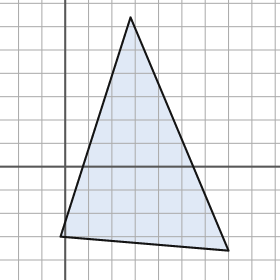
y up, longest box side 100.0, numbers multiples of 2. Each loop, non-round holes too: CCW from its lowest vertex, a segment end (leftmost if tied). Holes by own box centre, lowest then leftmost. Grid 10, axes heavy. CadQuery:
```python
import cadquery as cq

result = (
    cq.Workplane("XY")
    .moveTo(70.0, -36.0)
    .lineTo(28.0, 64.0)
    .lineTo(-2.0, -30.0)
    .close()
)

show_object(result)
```